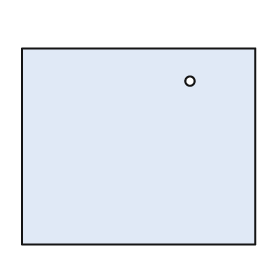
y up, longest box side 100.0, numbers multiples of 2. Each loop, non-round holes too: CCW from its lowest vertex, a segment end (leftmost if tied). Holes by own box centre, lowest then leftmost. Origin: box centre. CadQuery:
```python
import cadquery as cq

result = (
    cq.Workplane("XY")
    .moveTo(-50.0, -42.0)
    .lineTo(50.0, -42.0)
    .lineTo(50.0, 42.0)
    .lineTo(-50.0, 42.0)
    .close()
    .moveTo(22.0, 28.0)
    .circle(2.0)
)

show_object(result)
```